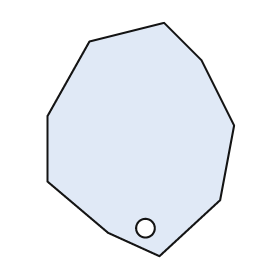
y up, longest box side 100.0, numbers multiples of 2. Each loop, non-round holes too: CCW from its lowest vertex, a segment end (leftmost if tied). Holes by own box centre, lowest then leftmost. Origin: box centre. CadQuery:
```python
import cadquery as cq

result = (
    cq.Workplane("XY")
    .moveTo(8.0, -50.0)
    .lineTo(34.0, -26.0)
    .lineTo(40.0, 6.0)
    .lineTo(26.0, 34.0)
    .lineTo(10.0, 50.0)
    .lineTo(-22.0, 42.0)
    .lineTo(-40.0, 10.0)
    .lineTo(-40.0, -18.0)
    .lineTo(-14.0, -40.0)
    .close()
    .moveTo(2.0, -38.0)
    .circle(4.0)
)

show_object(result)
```